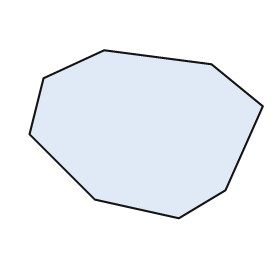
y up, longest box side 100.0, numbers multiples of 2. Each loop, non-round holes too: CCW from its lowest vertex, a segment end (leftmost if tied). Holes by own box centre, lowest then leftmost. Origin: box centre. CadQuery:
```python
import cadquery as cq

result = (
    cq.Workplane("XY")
    .moveTo(14.0, -36.0)
    .lineTo(34.0, -24.0)
    .lineTo(50.0, 12.0)
    .lineTo(28.0, 30.0)
    .lineTo(-18.0, 36.0)
    .lineTo(-44.0, 24.0)
    .lineTo(-50.0, 0.0)
    .lineTo(-22.0, -28.0)
    .close()
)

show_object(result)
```